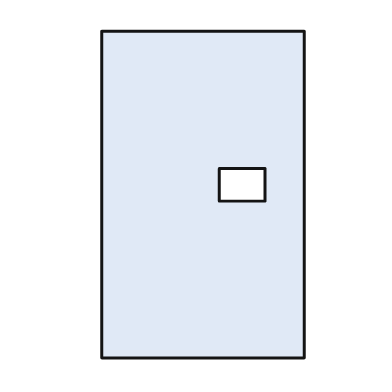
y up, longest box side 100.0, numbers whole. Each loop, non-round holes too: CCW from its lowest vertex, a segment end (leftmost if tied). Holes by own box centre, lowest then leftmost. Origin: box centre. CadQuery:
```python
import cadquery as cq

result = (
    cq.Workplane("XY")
    .moveTo(-31.0, -50.0)
    .lineTo(31.0, -50.0)
    .lineTo(31.0, 50.0)
    .lineTo(-31.0, 50.0)
    .close()
    .moveTo(5.0, -2.0)
    .lineTo(19.0, -2.0)
    .lineTo(19.0, 8.0)
    .lineTo(5.0, 8.0)
    .close()
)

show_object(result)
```